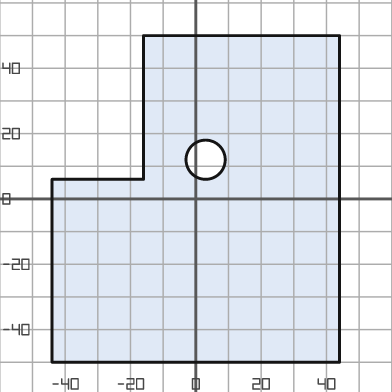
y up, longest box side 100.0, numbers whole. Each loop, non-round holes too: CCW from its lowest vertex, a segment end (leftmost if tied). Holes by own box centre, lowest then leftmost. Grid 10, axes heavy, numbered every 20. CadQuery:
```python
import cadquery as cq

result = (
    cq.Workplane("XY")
    .moveTo(-44.0, -50.0)
    .lineTo(44.0, -50.0)
    .lineTo(44.0, 50.0)
    .lineTo(-16.0, 50.0)
    .lineTo(-16.0, 6.0)
    .lineTo(-44.0, 6.0)
    .close()
    .moveTo(3.0, 12.0)
    .circle(6.0)
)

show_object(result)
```